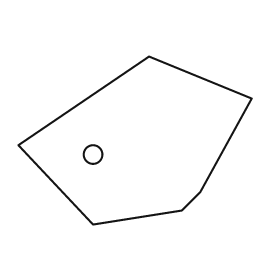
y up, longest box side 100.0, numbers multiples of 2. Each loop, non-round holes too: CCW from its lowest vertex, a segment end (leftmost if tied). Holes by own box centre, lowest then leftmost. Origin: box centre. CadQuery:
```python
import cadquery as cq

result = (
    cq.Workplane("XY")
    .moveTo(-18.0, -36.0)
    .lineTo(20.0, -30.0)
    .lineTo(28.0, -22.0)
    .lineTo(50.0, 18.0)
    .lineTo(6.0, 36.0)
    .lineTo(-50.0, -2.0)
    .close()
    .moveTo(-18.0, -6.0)
    .circle(4.0)
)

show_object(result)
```